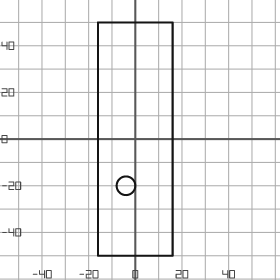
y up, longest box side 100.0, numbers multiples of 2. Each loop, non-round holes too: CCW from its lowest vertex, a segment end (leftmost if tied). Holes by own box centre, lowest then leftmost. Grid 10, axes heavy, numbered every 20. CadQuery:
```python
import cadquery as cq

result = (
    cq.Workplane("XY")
    .moveTo(-16.0, -50.0)
    .lineTo(16.0, -50.0)
    .lineTo(16.0, 50.0)
    .lineTo(-16.0, 50.0)
    .close()
    .moveTo(-4.0, -20.0)
    .circle(4.0)
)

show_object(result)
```